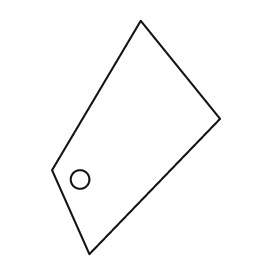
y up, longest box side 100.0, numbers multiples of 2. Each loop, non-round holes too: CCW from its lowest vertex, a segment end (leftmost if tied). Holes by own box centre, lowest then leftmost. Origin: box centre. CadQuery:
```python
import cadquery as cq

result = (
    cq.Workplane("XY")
    .moveTo(-20.0, -50.0)
    .lineTo(36.0, 8.0)
    .lineTo(2.0, 50.0)
    .lineTo(-36.0, -14.0)
    .close()
    .moveTo(-24.0, -18.0)
    .circle(4.0)
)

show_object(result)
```